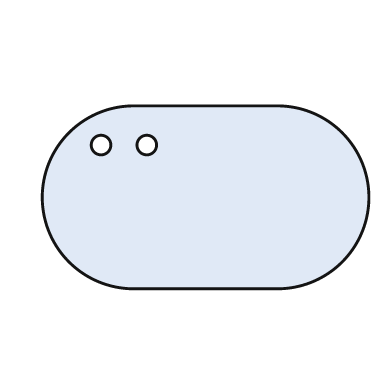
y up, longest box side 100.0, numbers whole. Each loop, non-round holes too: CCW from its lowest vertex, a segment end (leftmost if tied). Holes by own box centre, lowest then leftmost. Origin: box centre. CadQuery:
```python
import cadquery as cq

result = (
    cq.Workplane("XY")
    .moveTo(-22.0, -28.0)
    .lineTo(22.0, -28.0)
    .threePointArc((50.0, 0.0), (22.0, 28.0))
    .lineTo(-22.0, 28.0)
    .threePointArc((-50.0, 0.0), (-22.0, -28.0))
    .close()
    .moveTo(-32.0, 16.0)
    .circle(3.0)
    .moveTo(-18.0, 16.0)
    .circle(3.0)
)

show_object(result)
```